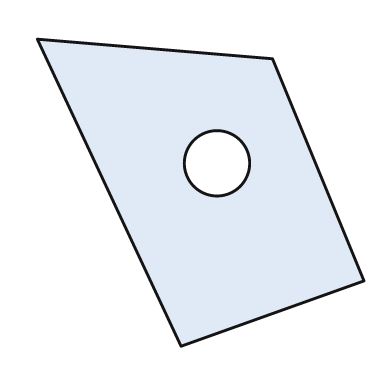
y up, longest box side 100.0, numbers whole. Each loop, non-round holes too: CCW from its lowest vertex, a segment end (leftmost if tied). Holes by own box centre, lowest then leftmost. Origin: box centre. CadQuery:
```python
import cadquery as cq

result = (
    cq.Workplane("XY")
    .moveTo(-6.0, -47.0)
    .lineTo(50.0, -27.0)
    .lineTo(22.0, 41.0)
    .lineTo(-50.0, 47.0)
    .close()
    .moveTo(5.0, 9.0)
    .circle(10.0)
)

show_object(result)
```